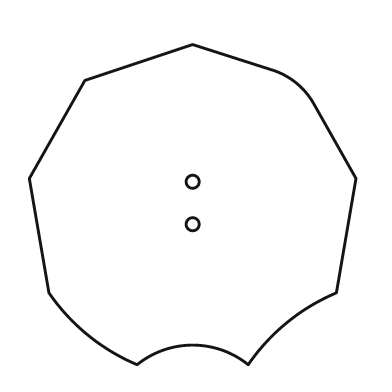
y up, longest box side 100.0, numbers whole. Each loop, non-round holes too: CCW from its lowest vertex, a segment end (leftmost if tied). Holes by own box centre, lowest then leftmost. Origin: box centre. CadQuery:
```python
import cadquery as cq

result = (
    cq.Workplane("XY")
    .moveTo(-17.0, -49.0)
    .threePointArc((0.0, -43.0), (17.0, -49.0))
    .threePointArc((29.0, -36.0), (44.0, -27.0))
    .lineTo(50.0, 8.0)
    .lineTo(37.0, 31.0)
    .threePointArc((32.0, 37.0), (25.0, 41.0))
    .lineTo(0.0, 49.0)
    .lineTo(-33.0, 38.0)
    .lineTo(-50.0, 8.0)
    .lineTo(-44.0, -27.0)
    .threePointArc((-32.0, -40.0), (-17.0, -49.0))
    .close()
    .moveTo(0.0, -6.0)
    .circle(2.0)
    .moveTo(0.0, 7.0)
    .circle(2.0)
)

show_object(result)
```